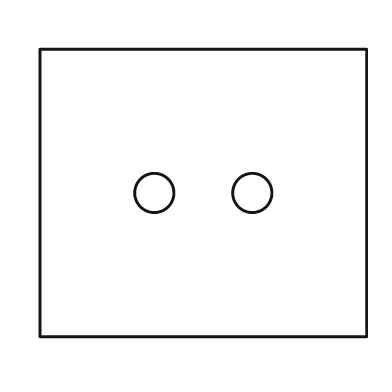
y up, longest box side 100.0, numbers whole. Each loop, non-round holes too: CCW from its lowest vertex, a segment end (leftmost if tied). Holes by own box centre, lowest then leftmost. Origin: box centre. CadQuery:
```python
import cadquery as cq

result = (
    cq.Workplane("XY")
    .moveTo(-50.0, -44.0)
    .lineTo(50.0, -44.0)
    .lineTo(50.0, 44.0)
    .lineTo(-50.0, 44.0)
    .close()
    .moveTo(-15.0, 0.0)
    .circle(6.0)
    .moveTo(15.0, 0.0)
    .circle(6.0)
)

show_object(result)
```